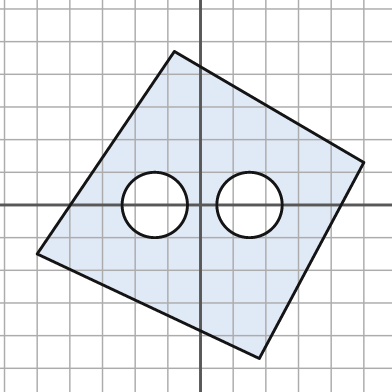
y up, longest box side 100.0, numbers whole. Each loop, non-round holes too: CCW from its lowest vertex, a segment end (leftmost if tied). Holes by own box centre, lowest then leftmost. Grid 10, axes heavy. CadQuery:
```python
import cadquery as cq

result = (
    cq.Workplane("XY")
    .moveTo(18.0, -47.0)
    .lineTo(50.0, 13.0)
    .lineTo(-8.0, 47.0)
    .lineTo(-50.0, -15.0)
    .close()
    .moveTo(-14.0, 0.0)
    .circle(10.0)
    .moveTo(15.0, 0.0)
    .circle(10.0)
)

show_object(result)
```